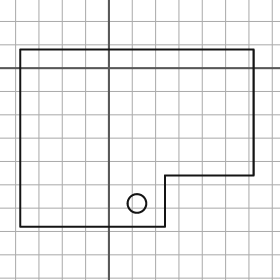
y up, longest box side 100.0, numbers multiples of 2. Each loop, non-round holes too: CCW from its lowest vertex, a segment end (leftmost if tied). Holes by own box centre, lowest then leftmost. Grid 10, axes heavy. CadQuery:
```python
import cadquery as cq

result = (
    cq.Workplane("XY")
    .moveTo(-38.0, -68.0)
    .lineTo(24.0, -68.0)
    .lineTo(24.0, -46.0)
    .lineTo(62.0, -46.0)
    .lineTo(62.0, 8.0)
    .lineTo(-38.0, 8.0)
    .close()
    .moveTo(12.0, -58.0)
    .circle(4.0)
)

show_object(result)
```